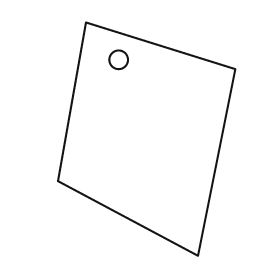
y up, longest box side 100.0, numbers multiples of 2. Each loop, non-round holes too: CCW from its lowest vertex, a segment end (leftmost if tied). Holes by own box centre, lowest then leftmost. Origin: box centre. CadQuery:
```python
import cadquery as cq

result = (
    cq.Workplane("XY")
    .moveTo(22.0, -50.0)
    .lineTo(38.0, 30.0)
    .lineTo(-26.0, 50.0)
    .lineTo(-38.0, -18.0)
    .close()
    .moveTo(-12.0, 34.0)
    .circle(4.0)
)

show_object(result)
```